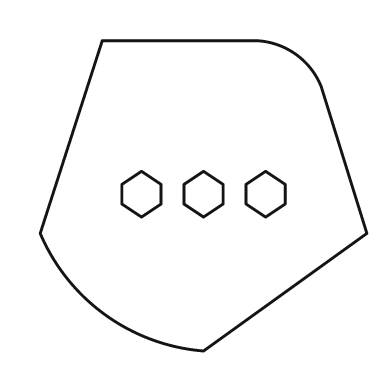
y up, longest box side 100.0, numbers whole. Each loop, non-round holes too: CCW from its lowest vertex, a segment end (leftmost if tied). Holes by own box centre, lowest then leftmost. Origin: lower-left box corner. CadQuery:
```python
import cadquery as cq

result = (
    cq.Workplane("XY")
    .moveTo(50.0, 0.0)
    .lineTo(100.0, 36.0)
    .lineTo(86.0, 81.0)
    .threePointArc((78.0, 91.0), (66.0, 95.0))
    .lineTo(19.0, 95.0)
    .lineTo(0.0, 36.0)
    .threePointArc((20.0, 11.0), (50.0, 0.0))
    .close()
    .moveTo(31.0, 41.0)
    .lineTo(37.0, 45.0)
    .lineTo(37.0, 51.0)
    .lineTo(31.0, 55.0)
    .lineTo(25.0, 51.0)
    .lineTo(25.0, 45.0)
    .close()
    .moveTo(50.0, 41.0)
    .lineTo(56.0, 45.0)
    .lineTo(56.0, 51.0)
    .lineTo(50.0, 55.0)
    .lineTo(44.0, 51.0)
    .lineTo(44.0, 45.0)
    .close()
    .moveTo(69.0, 41.0)
    .lineTo(75.0, 45.0)
    .lineTo(75.0, 51.0)
    .lineTo(69.0, 55.0)
    .lineTo(63.0, 51.0)
    .lineTo(63.0, 45.0)
    .close()
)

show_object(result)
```